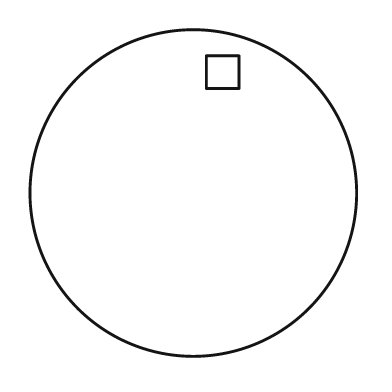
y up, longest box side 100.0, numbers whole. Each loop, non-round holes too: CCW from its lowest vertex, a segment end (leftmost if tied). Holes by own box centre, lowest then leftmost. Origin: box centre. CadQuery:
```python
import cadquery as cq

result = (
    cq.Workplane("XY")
    .moveTo(0.0, 0.0)
    .circle(50.0)
    .moveTo(4.0, 32.0)
    .lineTo(14.0, 32.0)
    .lineTo(14.0, 42.0)
    .lineTo(4.0, 42.0)
    .close()
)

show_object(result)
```